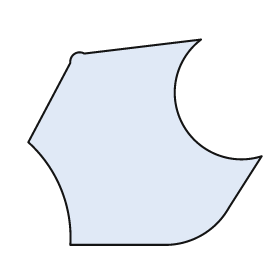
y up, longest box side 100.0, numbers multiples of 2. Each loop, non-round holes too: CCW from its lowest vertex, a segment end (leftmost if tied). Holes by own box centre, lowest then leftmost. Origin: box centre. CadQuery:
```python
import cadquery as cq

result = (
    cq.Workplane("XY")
    .moveTo(-32.0, -44.0)
    .lineTo(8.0, -44.0)
    .threePointArc((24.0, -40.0), (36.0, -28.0))
    .lineTo(50.0, -6.0)
    .threePointArc((16.0, 8.0), (24.0, 44.0))
    .lineTo(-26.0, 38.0)
    .threePointArc((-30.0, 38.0), (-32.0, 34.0))
    .lineTo(-50.0, 0.0)
    .threePointArc((-36.0, -20.0), (-32.0, -44.0))
    .close()
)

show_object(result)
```